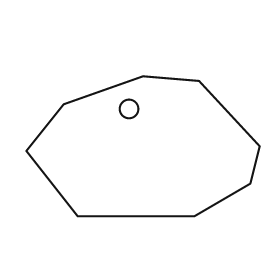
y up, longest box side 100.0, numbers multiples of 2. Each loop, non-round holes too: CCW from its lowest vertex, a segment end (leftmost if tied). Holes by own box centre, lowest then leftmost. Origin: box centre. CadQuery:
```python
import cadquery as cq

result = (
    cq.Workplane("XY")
    .moveTo(-28.0, -30.0)
    .lineTo(22.0, -30.0)
    .lineTo(46.0, -16.0)
    .lineTo(50.0, 0.0)
    .lineTo(24.0, 28.0)
    .lineTo(0.0, 30.0)
    .lineTo(-34.0, 18.0)
    .lineTo(-50.0, -2.0)
    .close()
    .moveTo(-6.0, 16.0)
    .circle(4.0)
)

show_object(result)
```